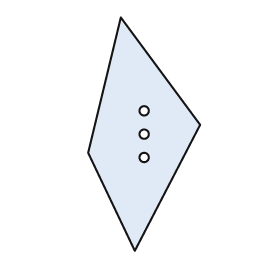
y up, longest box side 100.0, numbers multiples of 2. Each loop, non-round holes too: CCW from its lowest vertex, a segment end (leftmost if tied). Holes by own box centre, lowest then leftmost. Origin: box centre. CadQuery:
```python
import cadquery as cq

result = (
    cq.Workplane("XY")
    .moveTo(-4.0, -50.0)
    .lineTo(24.0, 4.0)
    .lineTo(-10.0, 50.0)
    .lineTo(-24.0, -8.0)
    .close()
    .moveTo(0.0, -10.0)
    .circle(2.0)
    .moveTo(0.0, 0.0)
    .circle(2.0)
    .moveTo(0.0, 10.0)
    .circle(2.0)
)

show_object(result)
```